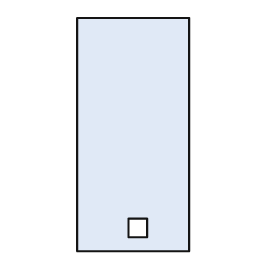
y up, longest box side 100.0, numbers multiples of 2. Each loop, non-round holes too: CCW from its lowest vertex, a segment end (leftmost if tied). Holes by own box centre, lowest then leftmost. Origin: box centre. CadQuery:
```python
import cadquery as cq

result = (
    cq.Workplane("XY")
    .moveTo(-24.0, -50.0)
    .lineTo(24.0, -50.0)
    .lineTo(24.0, 50.0)
    .lineTo(-24.0, 50.0)
    .close()
    .moveTo(-2.0, -44.0)
    .lineTo(6.0, -44.0)
    .lineTo(6.0, -36.0)
    .lineTo(-2.0, -36.0)
    .close()
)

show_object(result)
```